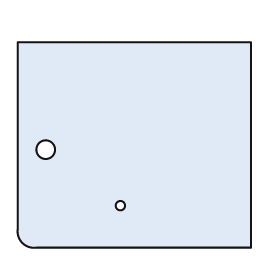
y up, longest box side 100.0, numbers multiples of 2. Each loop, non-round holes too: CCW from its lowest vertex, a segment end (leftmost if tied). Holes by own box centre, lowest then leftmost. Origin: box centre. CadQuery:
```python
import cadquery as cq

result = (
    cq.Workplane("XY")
    .moveTo(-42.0, -44.0)
    .lineTo(50.0, -44.0)
    .lineTo(50.0, 44.0)
    .lineTo(-50.0, 44.0)
    .lineTo(-50.0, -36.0)
    .threePointArc((-48.0, -42.0), (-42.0, -44.0))
    .close()
    .moveTo(-6.0, -26.0)
    .circle(2.0)
    .moveTo(-38.0, -2.0)
    .circle(4.0)
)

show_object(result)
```